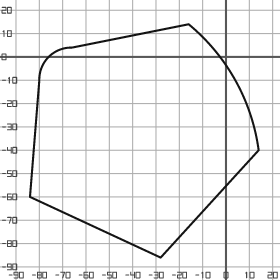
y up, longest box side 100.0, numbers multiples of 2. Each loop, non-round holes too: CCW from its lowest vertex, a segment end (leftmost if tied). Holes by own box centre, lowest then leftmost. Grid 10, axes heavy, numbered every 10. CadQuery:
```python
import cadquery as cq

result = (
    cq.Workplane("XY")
    .moveTo(-28.0, -86.0)
    .lineTo(14.0, -40.0)
    .threePointArc((4.0, -10.0), (-16.0, 14.0))
    .lineTo(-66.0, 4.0)
    .threePointArc((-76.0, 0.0), (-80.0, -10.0))
    .lineTo(-84.0, -60.0)
    .close()
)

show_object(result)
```